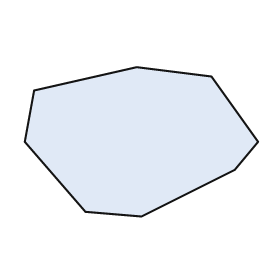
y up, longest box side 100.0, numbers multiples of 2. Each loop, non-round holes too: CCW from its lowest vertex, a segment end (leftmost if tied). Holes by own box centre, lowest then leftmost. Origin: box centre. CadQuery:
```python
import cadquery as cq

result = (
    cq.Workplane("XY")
    .moveTo(0.0, -32.0)
    .lineTo(40.0, -12.0)
    .lineTo(50.0, 0.0)
    .lineTo(30.0, 28.0)
    .lineTo(-2.0, 32.0)
    .lineTo(-46.0, 22.0)
    .lineTo(-50.0, 0.0)
    .lineTo(-24.0, -30.0)
    .close()
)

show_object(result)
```